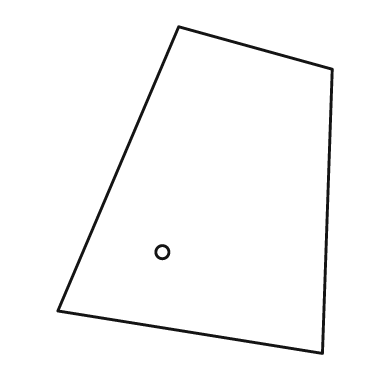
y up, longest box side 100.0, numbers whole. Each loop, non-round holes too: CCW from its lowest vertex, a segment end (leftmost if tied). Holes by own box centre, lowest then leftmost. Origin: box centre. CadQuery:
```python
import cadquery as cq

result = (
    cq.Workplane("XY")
    .moveTo(39.0, -50.0)
    .lineTo(42.0, 37.0)
    .lineTo(-5.0, 50.0)
    .lineTo(-42.0, -37.0)
    .close()
    .moveTo(-10.0, -19.0)
    .circle(2.0)
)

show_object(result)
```